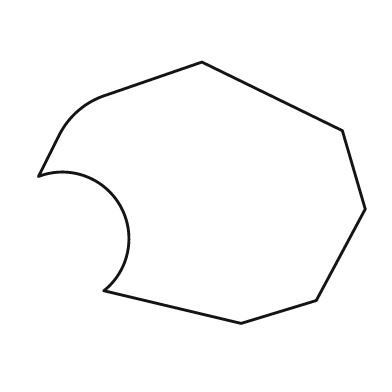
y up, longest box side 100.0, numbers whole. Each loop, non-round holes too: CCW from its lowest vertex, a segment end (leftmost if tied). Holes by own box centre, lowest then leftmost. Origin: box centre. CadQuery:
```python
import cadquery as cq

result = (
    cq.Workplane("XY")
    .moveTo(12.0, -40.0)
    .lineTo(35.0, -33.0)
    .lineTo(50.0, -5.0)
    .lineTo(43.0, 19.0)
    .lineTo(0.0, 40.0)
    .lineTo(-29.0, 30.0)
    .threePointArc((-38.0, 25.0), (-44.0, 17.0))
    .lineTo(-50.0, 5.0)
    .threePointArc((-25.0, -4.0), (-30.0, -30.0))
    .close()
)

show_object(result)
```